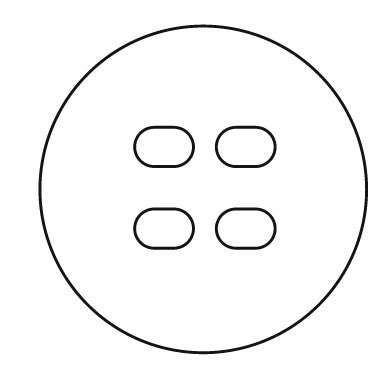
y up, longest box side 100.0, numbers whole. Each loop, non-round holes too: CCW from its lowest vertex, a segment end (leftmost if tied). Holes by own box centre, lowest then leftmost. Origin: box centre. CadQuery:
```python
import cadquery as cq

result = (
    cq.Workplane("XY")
    .moveTo(0.0, 0.0)
    .circle(50.0)
    .moveTo(-15.0, -18.0)
    .lineTo(-9.0, -18.0)
    .threePointArc((-3.0, -12.0), (-9.0, -6.0))
    .lineTo(-15.0, -6.0)
    .threePointArc((-21.0, -12.0), (-15.0, -18.0))
    .close()
    .moveTo(10.0, -18.0)
    .lineTo(16.0, -18.0)
    .threePointArc((22.0, -12.0), (16.0, -6.0))
    .lineTo(10.0, -6.0)
    .threePointArc((4.0, -12.0), (10.0, -18.0))
    .close()
    .moveTo(-15.0, 7.0)
    .lineTo(-9.0, 7.0)
    .threePointArc((-3.0, 13.0), (-9.0, 19.0))
    .lineTo(-15.0, 19.0)
    .threePointArc((-21.0, 13.0), (-15.0, 7.0))
    .close()
    .moveTo(10.0, 7.0)
    .lineTo(16.0, 7.0)
    .threePointArc((22.0, 13.0), (16.0, 19.0))
    .lineTo(10.0, 19.0)
    .threePointArc((4.0, 13.0), (10.0, 7.0))
    .close()
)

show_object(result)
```